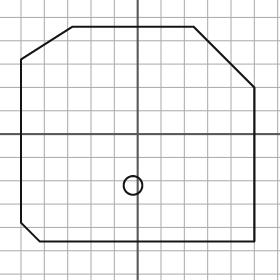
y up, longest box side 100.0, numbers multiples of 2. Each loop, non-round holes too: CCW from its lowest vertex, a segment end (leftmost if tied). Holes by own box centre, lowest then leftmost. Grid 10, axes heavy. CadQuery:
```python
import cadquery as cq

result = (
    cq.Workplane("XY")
    .moveTo(-42.0, -46.0)
    .lineTo(50.0, -46.0)
    .lineTo(50.0, 20.0)
    .lineTo(24.0, 46.0)
    .lineTo(-28.0, 46.0)
    .lineTo(-50.0, 32.0)
    .lineTo(-50.0, -38.0)
    .close()
    .moveTo(-2.0, -22.0)
    .circle(4.0)
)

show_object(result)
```